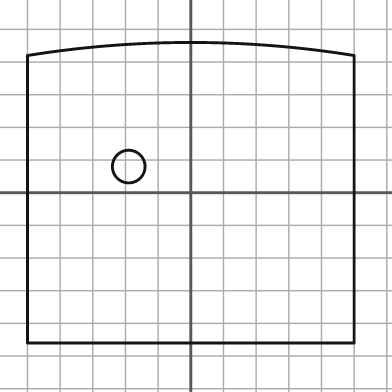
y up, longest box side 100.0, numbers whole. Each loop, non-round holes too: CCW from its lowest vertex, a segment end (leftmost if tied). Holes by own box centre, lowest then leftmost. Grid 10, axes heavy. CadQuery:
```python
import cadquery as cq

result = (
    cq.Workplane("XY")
    .moveTo(-50.0, -46.0)
    .lineTo(50.0, -46.0)
    .lineTo(50.0, 42.0)
    .threePointArc((0.0, 46.0), (-50.0, 42.0))
    .close()
    .moveTo(-19.0, 8.0)
    .circle(5.0)
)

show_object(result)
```